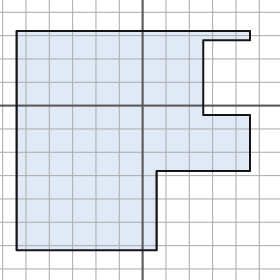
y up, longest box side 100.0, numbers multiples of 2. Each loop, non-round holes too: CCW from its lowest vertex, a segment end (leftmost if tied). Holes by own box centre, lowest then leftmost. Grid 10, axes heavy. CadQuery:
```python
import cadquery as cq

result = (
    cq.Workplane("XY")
    .moveTo(-54.0, -62.0)
    .lineTo(6.0, -62.0)
    .lineTo(6.0, -28.0)
    .lineTo(46.0, -28.0)
    .lineTo(46.0, -4.0)
    .lineTo(26.0, -4.0)
    .lineTo(26.0, 28.0)
    .lineTo(46.0, 28.0)
    .lineTo(46.0, 32.0)
    .lineTo(-54.0, 32.0)
    .close()
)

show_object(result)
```